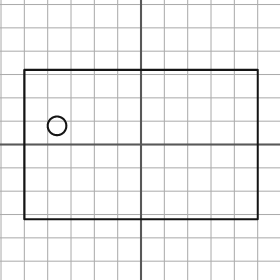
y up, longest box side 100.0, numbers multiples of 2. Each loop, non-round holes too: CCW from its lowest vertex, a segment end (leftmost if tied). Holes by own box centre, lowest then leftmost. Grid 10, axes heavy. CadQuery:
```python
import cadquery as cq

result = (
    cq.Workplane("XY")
    .moveTo(-50.0, -32.0)
    .lineTo(50.0, -32.0)
    .lineTo(50.0, 32.0)
    .lineTo(-50.0, 32.0)
    .close()
    .moveTo(-36.0, 8.0)
    .circle(4.0)
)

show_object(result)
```